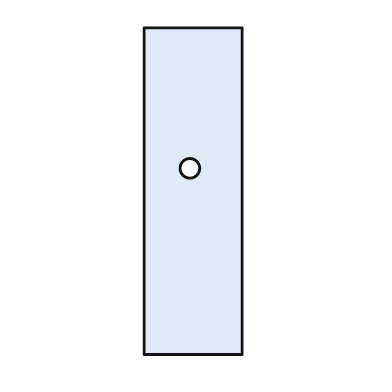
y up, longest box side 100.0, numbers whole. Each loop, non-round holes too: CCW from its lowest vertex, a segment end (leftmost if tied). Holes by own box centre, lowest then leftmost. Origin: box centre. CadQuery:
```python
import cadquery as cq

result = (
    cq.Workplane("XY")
    .moveTo(-15.0, -50.0)
    .lineTo(15.0, -50.0)
    .lineTo(15.0, 50.0)
    .lineTo(-15.0, 50.0)
    .close()
    .moveTo(-1.0, 7.0)
    .circle(3.0)
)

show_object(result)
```